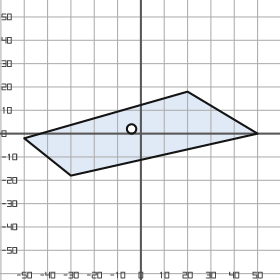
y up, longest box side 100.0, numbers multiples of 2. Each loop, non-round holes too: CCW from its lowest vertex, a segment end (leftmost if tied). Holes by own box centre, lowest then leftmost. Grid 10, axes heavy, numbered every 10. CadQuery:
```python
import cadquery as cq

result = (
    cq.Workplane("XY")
    .moveTo(-30.0, -18.0)
    .lineTo(50.0, 0.0)
    .lineTo(20.0, 18.0)
    .lineTo(-50.0, -2.0)
    .close()
    .moveTo(-4.0, 2.0)
    .circle(2.0)
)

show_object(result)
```